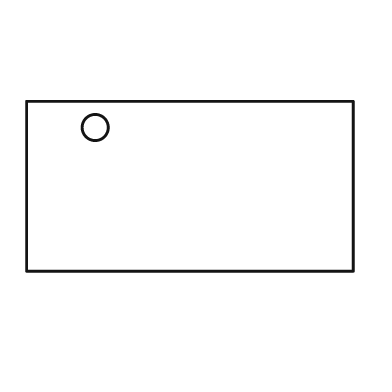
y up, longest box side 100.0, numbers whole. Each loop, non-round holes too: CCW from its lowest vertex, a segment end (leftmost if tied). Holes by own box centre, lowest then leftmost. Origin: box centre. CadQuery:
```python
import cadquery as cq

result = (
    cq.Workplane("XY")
    .moveTo(-50.0, -26.0)
    .lineTo(50.0, -26.0)
    .lineTo(50.0, 26.0)
    .lineTo(-50.0, 26.0)
    .close()
    .moveTo(-29.0, 18.0)
    .circle(4.0)
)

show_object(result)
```